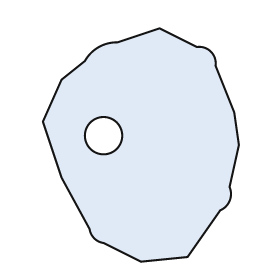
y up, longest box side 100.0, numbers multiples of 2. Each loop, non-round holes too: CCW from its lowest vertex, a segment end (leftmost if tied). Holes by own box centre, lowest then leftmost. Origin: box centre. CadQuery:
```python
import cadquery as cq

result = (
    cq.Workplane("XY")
    .moveTo(0.0, -50.0)
    .lineTo(20.0, -48.0)
    .lineTo(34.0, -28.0)
    .threePointArc((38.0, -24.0), (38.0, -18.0))
    .lineTo(42.0, 0.0)
    .lineTo(40.0, 14.0)
    .lineTo(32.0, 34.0)
    .threePointArc((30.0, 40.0), (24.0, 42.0))
    .lineTo(8.0, 50.0)
    .lineTo(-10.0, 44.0)
    .threePointArc((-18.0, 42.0), (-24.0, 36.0))
    .lineTo(-34.0, 28.0)
    .lineTo(-42.0, 10.0)
    .lineTo(-34.0, -14.0)
    .lineTo(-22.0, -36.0)
    .threePointArc((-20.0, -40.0), (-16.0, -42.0))
    .close()
    .moveTo(-16.0, 4.0)
    .circle(8.0)
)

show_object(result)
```